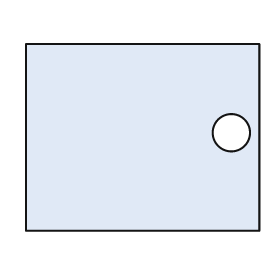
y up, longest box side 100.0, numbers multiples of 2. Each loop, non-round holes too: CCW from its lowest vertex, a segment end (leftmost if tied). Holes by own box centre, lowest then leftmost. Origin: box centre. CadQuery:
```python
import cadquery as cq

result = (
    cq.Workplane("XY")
    .moveTo(-50.0, -40.0)
    .lineTo(50.0, -40.0)
    .lineTo(50.0, 40.0)
    .lineTo(-50.0, 40.0)
    .close()
    .moveTo(38.0, 2.0)
    .circle(8.0)
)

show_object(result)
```